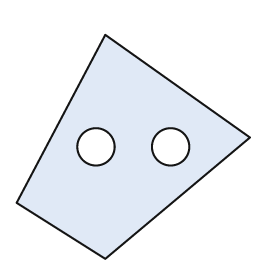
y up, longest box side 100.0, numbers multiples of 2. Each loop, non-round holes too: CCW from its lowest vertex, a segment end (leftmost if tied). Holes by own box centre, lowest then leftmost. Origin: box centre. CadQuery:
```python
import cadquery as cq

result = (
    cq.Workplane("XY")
    .moveTo(-12.0, -48.0)
    .lineTo(50.0, 4.0)
    .lineTo(-12.0, 48.0)
    .lineTo(-50.0, -24.0)
    .close()
    .moveTo(-16.0, 0.0)
    .circle(8.0)
    .moveTo(16.0, 0.0)
    .circle(8.0)
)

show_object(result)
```